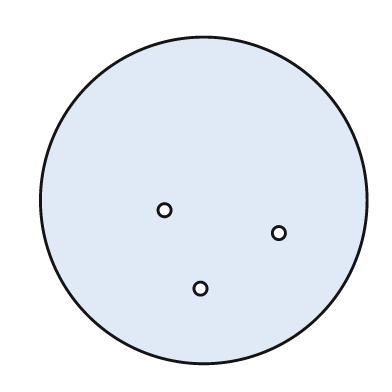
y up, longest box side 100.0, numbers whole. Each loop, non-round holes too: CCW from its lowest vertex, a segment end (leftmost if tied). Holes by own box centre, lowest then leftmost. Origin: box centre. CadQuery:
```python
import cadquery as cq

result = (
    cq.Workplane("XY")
    .moveTo(0.0, 0.0)
    .circle(50.0)
    .moveTo(-1.0, -27.0)
    .circle(2.0)
    .moveTo(23.0, -10.0)
    .circle(2.0)
    .moveTo(-12.0, -3.0)
    .circle(2.0)
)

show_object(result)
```